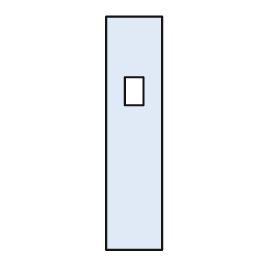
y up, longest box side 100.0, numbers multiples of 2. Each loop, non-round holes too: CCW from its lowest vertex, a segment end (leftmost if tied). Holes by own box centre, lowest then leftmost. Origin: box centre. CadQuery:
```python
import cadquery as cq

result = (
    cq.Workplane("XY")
    .moveTo(-12.0, -50.0)
    .lineTo(12.0, -50.0)
    .lineTo(12.0, 50.0)
    .lineTo(-12.0, 50.0)
    .close()
    .moveTo(-4.0, 12.0)
    .lineTo(4.0, 12.0)
    .lineTo(4.0, 24.0)
    .lineTo(-4.0, 24.0)
    .close()
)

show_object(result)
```